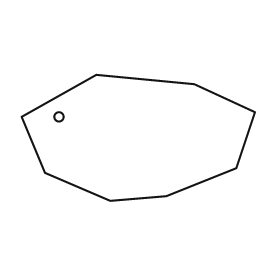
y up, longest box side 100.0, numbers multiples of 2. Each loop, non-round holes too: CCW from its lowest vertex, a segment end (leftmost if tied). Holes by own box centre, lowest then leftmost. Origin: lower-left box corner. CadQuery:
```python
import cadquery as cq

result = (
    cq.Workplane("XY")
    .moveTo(38.0, 0.0)
    .lineTo(62.0, 2.0)
    .lineTo(92.0, 14.0)
    .lineTo(100.0, 38.0)
    .lineTo(74.0, 50.0)
    .lineTo(32.0, 54.0)
    .lineTo(0.0, 36.0)
    .lineTo(10.0, 12.0)
    .close()
    .moveTo(16.0, 36.0)
    .circle(2.0)
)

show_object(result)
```